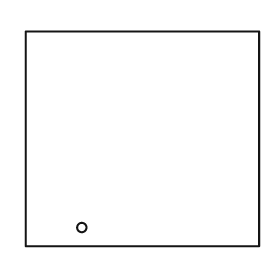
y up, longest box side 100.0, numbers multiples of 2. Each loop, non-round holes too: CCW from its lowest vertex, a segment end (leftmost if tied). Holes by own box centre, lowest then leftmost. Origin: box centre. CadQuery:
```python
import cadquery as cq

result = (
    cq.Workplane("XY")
    .moveTo(-50.0, -46.0)
    .lineTo(50.0, -46.0)
    .lineTo(50.0, 46.0)
    .lineTo(-50.0, 46.0)
    .close()
    .moveTo(-26.0, -38.0)
    .circle(2.0)
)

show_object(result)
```